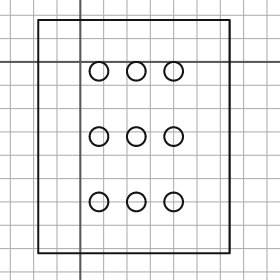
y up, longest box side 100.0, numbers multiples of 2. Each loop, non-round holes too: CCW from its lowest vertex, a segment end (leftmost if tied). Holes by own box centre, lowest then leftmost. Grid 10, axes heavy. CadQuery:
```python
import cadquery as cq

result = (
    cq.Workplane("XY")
    .moveTo(-18.0, -82.0)
    .lineTo(64.0, -82.0)
    .lineTo(64.0, 18.0)
    .lineTo(-18.0, 18.0)
    .close()
    .moveTo(8.0, -60.0)
    .circle(4.0)
    .moveTo(24.0, -60.0)
    .circle(4.0)
    .moveTo(40.0, -60.0)
    .circle(4.0)
    .moveTo(8.0, -32.0)
    .circle(4.0)
    .moveTo(24.0, -32.0)
    .circle(4.0)
    .moveTo(40.0, -32.0)
    .circle(4.0)
    .moveTo(8.0, -4.0)
    .circle(4.0)
    .moveTo(24.0, -4.0)
    .circle(4.0)
    .moveTo(40.0, -4.0)
    .circle(4.0)
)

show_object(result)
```